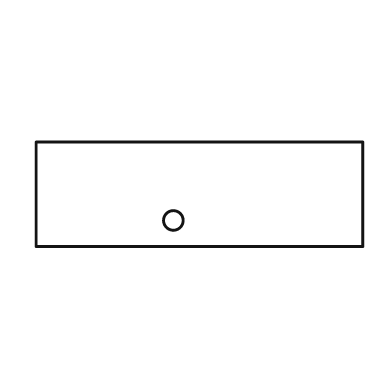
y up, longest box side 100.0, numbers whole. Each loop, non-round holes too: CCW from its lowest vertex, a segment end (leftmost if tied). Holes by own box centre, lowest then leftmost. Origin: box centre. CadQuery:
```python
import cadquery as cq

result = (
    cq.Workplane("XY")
    .moveTo(-50.0, -16.0)
    .lineTo(50.0, -16.0)
    .lineTo(50.0, 16.0)
    .lineTo(-50.0, 16.0)
    .close()
    .moveTo(-8.0, -8.0)
    .circle(3.0)
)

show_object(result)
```